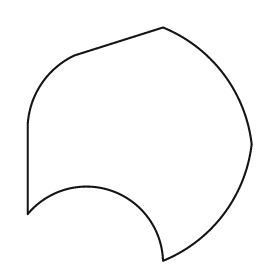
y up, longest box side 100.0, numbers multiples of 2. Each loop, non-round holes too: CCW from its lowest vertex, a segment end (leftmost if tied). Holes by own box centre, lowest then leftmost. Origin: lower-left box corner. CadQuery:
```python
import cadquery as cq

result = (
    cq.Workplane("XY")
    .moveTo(58.0, 0.0)
    .threePointArc((84.0, 20.0), (96.0, 50.0))
    .threePointArc((84.0, 80.0), (58.0, 100.0))
    .lineTo(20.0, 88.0)
    .threePointArc((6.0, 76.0), (0.0, 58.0))
    .lineTo(0.0, 20.0)
    .threePointArc((36.0, 30.0), (58.0, 0.0))
    .close()
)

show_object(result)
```